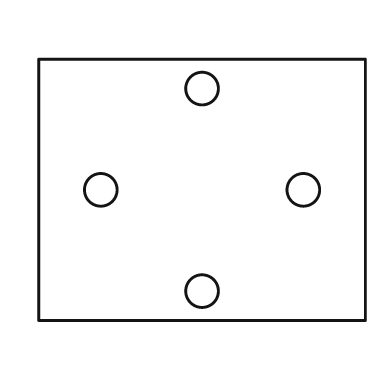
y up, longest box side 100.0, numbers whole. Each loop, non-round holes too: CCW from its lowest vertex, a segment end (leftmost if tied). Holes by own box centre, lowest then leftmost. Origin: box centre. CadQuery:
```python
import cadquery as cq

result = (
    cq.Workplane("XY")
    .moveTo(-50.0, -40.0)
    .lineTo(50.0, -40.0)
    .lineTo(50.0, 40.0)
    .lineTo(-50.0, 40.0)
    .close()
    .moveTo(0.0, -31.0)
    .circle(5.0)
    .moveTo(-31.0, 0.0)
    .circle(5.0)
    .moveTo(31.0, 0.0)
    .circle(5.0)
    .moveTo(0.0, 31.0)
    .circle(5.0)
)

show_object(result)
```